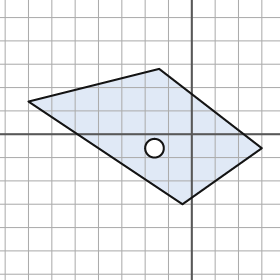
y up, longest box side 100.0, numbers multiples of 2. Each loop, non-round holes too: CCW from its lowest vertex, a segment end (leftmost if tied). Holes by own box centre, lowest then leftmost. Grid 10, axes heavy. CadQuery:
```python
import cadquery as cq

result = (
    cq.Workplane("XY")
    .moveTo(-4.0, -30.0)
    .lineTo(30.0, -6.0)
    .lineTo(-14.0, 28.0)
    .lineTo(-70.0, 14.0)
    .close()
    .moveTo(-16.0, -6.0)
    .circle(4.0)
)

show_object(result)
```